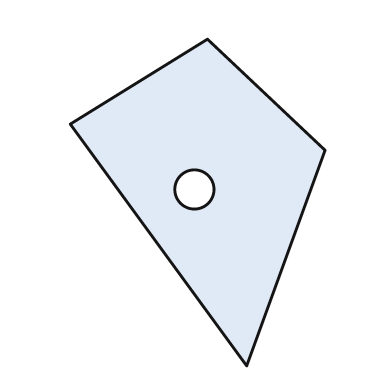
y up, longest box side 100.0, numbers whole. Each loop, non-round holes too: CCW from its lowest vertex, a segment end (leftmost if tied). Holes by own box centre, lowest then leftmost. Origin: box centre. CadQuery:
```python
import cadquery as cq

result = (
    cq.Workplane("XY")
    .moveTo(15.0, -50.0)
    .lineTo(39.0, 16.0)
    .lineTo(3.0, 50.0)
    .lineTo(-39.0, 24.0)
    .close()
    .moveTo(-1.0, 4.0)
    .circle(6.0)
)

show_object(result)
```